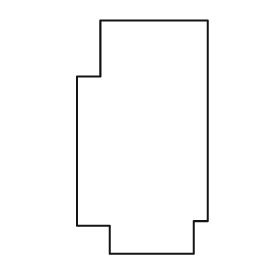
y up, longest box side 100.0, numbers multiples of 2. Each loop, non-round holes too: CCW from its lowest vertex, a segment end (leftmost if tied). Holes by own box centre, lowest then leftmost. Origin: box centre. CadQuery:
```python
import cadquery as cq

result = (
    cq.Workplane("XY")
    .moveTo(-14.0, -50.0)
    .lineTo(22.0, -50.0)
    .lineTo(22.0, -36.0)
    .lineTo(28.0, -36.0)
    .lineTo(28.0, 50.0)
    .lineTo(-18.0, 50.0)
    .lineTo(-18.0, 26.0)
    .lineTo(-28.0, 26.0)
    .lineTo(-28.0, -38.0)
    .lineTo(-14.0, -38.0)
    .close()
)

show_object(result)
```